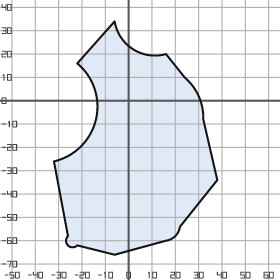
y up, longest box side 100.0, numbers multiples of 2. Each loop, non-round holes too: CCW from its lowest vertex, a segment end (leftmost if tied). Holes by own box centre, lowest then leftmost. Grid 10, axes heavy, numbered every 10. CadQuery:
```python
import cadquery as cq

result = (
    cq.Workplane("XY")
    .moveTo(-6.0, -66.0)
    .lineTo(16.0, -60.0)
    .threePointArc((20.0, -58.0), (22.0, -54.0))
    .lineTo(38.0, -34.0)
    .lineTo(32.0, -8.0)
    .threePointArc((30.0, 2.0), (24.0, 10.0))
    .lineTo(16.0, 20.0)
    .threePointArc((2.0, 22.0), (-6.0, 34.0))
    .lineTo(-22.0, 16.0)
    .threePointArc((-14.0, -8.0), (-32.0, -26.0))
    .lineTo(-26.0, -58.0)
    .threePointArc((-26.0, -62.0), (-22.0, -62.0))
    .close()
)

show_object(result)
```